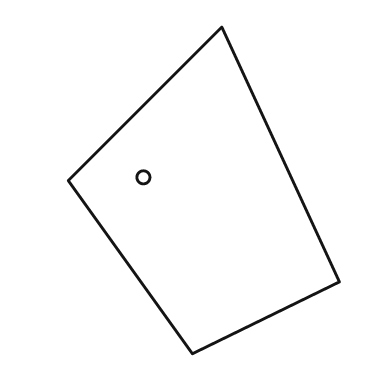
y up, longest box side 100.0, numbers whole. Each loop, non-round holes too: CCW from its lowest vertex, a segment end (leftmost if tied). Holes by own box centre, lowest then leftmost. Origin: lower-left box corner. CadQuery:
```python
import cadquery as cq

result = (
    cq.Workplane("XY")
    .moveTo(38.0, 0.0)
    .lineTo(83.0, 22.0)
    .lineTo(47.0, 100.0)
    .lineTo(0.0, 53.0)
    .close()
    .moveTo(23.0, 54.0)
    .circle(2.0)
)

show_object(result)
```